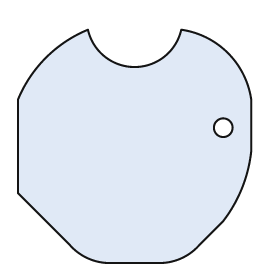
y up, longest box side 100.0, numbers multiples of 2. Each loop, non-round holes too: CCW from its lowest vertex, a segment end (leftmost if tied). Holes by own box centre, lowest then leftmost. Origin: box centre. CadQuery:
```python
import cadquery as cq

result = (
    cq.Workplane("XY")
    .moveTo(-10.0, -50.0)
    .lineTo(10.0, -50.0)
    .threePointArc((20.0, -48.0), (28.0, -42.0))
    .lineTo(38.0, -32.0)
    .threePointArc((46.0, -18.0), (50.0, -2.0))
    .lineTo(50.0, 20.0)
    .threePointArc((40.0, 40.0), (20.0, 50.0))
    .threePointArc((0.0, 34.0), (-20.0, 50.0))
    .threePointArc((-38.0, 38.0), (-50.0, 20.0))
    .lineTo(-50.0, -20.0)
    .lineTo(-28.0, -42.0)
    .threePointArc((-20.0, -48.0), (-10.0, -50.0))
    .close()
    .moveTo(38.0, 8.0)
    .circle(4.0)
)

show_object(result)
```